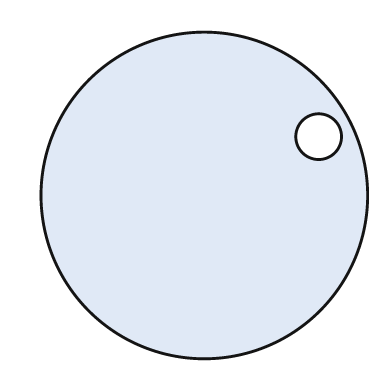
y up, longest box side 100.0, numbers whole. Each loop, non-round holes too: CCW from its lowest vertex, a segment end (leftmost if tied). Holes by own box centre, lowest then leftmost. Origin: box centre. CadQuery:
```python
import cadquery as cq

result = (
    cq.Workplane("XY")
    .moveTo(0.0, 0.0)
    .circle(50.0)
    .moveTo(35.0, 18.0)
    .circle(7.0)
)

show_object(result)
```